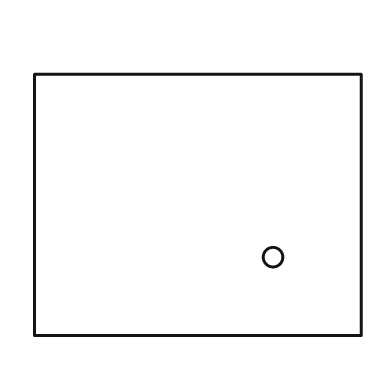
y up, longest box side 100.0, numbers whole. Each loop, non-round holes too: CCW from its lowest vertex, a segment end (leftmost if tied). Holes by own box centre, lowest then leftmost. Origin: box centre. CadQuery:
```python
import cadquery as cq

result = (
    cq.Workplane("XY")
    .moveTo(-50.0, -40.0)
    .lineTo(50.0, -40.0)
    .lineTo(50.0, 40.0)
    .lineTo(-50.0, 40.0)
    .close()
    .moveTo(23.0, -16.0)
    .circle(3.0)
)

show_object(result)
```